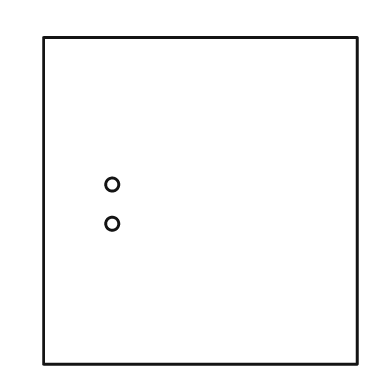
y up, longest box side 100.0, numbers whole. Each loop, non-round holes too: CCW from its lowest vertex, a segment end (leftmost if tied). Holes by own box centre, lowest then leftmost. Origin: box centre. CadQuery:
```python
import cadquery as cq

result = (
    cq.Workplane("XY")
    .moveTo(-48.0, -50.0)
    .lineTo(48.0, -50.0)
    .lineTo(48.0, 50.0)
    .lineTo(-48.0, 50.0)
    .close()
    .moveTo(-27.0, -7.0)
    .circle(2.0)
    .moveTo(-27.0, 5.0)
    .circle(2.0)
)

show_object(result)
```